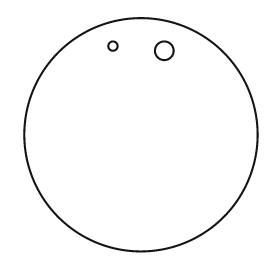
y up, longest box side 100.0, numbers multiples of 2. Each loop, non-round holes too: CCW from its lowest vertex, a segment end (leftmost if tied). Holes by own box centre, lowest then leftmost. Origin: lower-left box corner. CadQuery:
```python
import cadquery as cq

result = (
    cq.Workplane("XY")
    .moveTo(50.0, 50.0)
    .circle(50.0)
    .moveTo(60.0, 86.0)
    .circle(4.0)
    .moveTo(38.0, 88.0)
    .circle(2.0)
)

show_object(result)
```